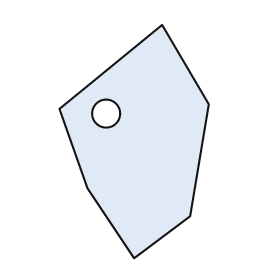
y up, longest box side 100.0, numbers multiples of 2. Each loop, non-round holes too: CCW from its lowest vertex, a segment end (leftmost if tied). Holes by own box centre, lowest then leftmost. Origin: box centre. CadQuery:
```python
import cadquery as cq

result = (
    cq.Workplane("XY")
    .moveTo(0.0, -50.0)
    .lineTo(24.0, -32.0)
    .lineTo(32.0, 16.0)
    .lineTo(12.0, 50.0)
    .lineTo(-32.0, 14.0)
    .lineTo(-20.0, -20.0)
    .close()
    .moveTo(-12.0, 12.0)
    .circle(6.0)
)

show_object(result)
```